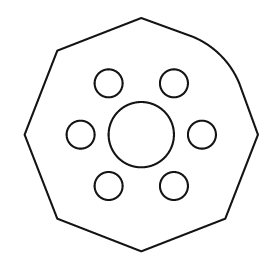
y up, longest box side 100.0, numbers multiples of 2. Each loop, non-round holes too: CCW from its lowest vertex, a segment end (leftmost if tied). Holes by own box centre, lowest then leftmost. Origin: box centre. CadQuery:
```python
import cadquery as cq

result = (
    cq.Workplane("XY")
    .moveTo(0.0, -50.0)
    .lineTo(36.0, -36.0)
    .lineTo(50.0, 0.0)
    .lineTo(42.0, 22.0)
    .threePointArc((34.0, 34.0), (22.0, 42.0))
    .lineTo(0.0, 50.0)
    .lineTo(-36.0, 36.0)
    .lineTo(-50.0, 0.0)
    .lineTo(-36.0, -36.0)
    .close()
    .moveTo(-14.0, -22.0)
    .circle(6.0)
    .moveTo(14.0, -22.0)
    .circle(6.0)
    .moveTo(-26.0, 0.0)
    .circle(6.0)
    .moveTo(0.0, 0.0)
    .circle(14.0)
    .moveTo(26.0, 0.0)
    .circle(6.0)
    .moveTo(-14.0, 22.0)
    .circle(6.0)
    .moveTo(14.0, 22.0)
    .circle(6.0)
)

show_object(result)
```